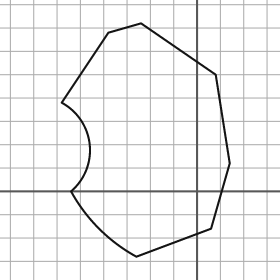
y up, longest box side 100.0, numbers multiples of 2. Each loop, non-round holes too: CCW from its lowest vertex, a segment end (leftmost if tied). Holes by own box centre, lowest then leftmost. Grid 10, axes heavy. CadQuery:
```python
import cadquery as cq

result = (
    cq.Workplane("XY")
    .moveTo(-26.0, -28.0)
    .lineTo(6.0, -16.0)
    .lineTo(14.0, 12.0)
    .lineTo(8.0, 50.0)
    .lineTo(-24.0, 72.0)
    .lineTo(-38.0, 68.0)
    .lineTo(-58.0, 38.0)
    .threePointArc((-46.0, 20.0), (-54.0, 0.0))
    .threePointArc((-42.0, -16.0), (-26.0, -28.0))
    .close()
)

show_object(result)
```